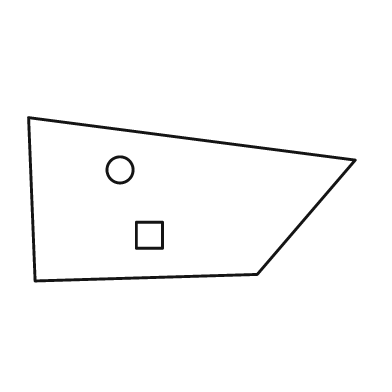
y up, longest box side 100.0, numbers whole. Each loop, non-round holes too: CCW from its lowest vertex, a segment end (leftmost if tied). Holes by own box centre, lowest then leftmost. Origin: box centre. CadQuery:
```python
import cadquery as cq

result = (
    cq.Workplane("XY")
    .moveTo(-48.0, -25.0)
    .lineTo(20.0, -23.0)
    .lineTo(50.0, 12.0)
    .lineTo(-50.0, 25.0)
    .close()
    .moveTo(-17.0, -15.0)
    .lineTo(-9.0, -15.0)
    .lineTo(-9.0, -7.0)
    .lineTo(-17.0, -7.0)
    .close()
    .moveTo(-22.0, 9.0)
    .circle(4.0)
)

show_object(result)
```